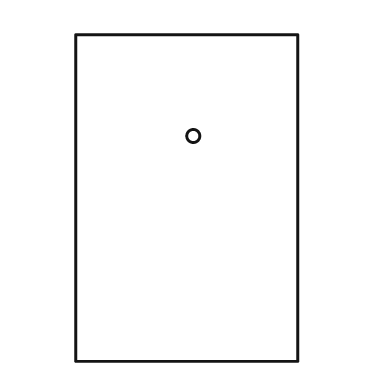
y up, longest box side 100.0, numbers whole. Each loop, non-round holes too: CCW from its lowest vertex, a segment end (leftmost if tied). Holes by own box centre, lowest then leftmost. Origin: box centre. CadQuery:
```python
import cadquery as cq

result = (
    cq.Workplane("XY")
    .moveTo(-34.0, -50.0)
    .lineTo(34.0, -50.0)
    .lineTo(34.0, 50.0)
    .lineTo(-34.0, 50.0)
    .close()
    .moveTo(2.0, 19.0)
    .circle(2.0)
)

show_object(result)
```